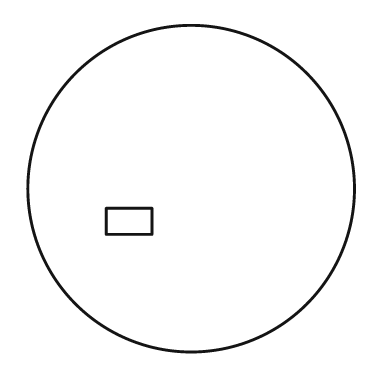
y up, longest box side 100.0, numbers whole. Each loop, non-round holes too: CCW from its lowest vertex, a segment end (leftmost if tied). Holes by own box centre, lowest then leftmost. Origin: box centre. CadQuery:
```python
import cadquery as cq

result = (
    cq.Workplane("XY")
    .moveTo(0.0, 0.0)
    .circle(50.0)
    .moveTo(-26.0, -14.0)
    .lineTo(-12.0, -14.0)
    .lineTo(-12.0, -6.0)
    .lineTo(-26.0, -6.0)
    .close()
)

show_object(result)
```